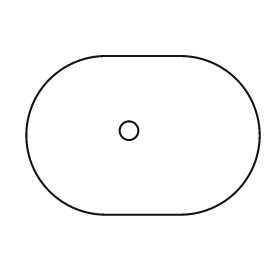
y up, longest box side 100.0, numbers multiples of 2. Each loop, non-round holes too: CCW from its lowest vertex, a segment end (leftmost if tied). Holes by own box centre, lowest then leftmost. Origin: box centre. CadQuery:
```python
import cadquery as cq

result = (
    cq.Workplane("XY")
    .moveTo(-16.0, -34.0)
    .lineTo(16.0, -34.0)
    .threePointArc((50.0, 0.0), (16.0, 34.0))
    .lineTo(-16.0, 34.0)
    .threePointArc((-50.0, 0.0), (-16.0, -34.0))
    .close()
    .moveTo(-6.0, 2.0)
    .circle(4.0)
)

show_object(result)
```